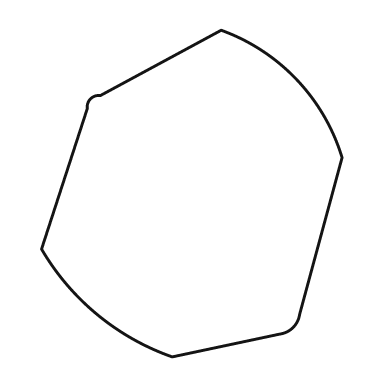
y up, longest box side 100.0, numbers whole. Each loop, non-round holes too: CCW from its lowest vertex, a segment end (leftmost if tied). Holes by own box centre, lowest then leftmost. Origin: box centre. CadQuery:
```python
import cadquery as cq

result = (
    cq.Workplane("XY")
    .moveTo(-6.0, -50.0)
    .lineTo(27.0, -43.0)
    .threePointArc((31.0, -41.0), (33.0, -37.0))
    .lineTo(46.0, 11.0)
    .threePointArc((32.0, 35.0), (9.0, 50.0))
    .lineTo(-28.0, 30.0)
    .threePointArc((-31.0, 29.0), (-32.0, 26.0))
    .lineTo(-46.0, -17.0)
    .threePointArc((-29.0, -37.0), (-6.0, -50.0))
    .close()
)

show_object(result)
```